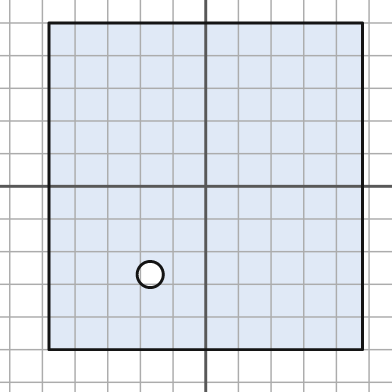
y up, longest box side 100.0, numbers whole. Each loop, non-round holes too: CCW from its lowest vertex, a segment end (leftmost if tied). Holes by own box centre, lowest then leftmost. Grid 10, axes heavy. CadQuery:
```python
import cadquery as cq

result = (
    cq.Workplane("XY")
    .moveTo(-48.0, -50.0)
    .lineTo(48.0, -50.0)
    .lineTo(48.0, 50.0)
    .lineTo(-48.0, 50.0)
    .close()
    .moveTo(-17.0, -27.0)
    .circle(4.0)
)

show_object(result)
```